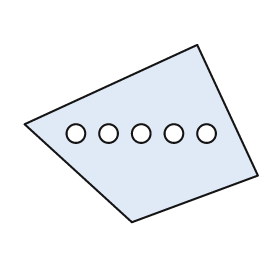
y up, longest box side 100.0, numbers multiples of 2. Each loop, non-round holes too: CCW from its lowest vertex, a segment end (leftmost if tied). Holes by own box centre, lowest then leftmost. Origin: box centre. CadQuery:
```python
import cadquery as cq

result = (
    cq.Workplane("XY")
    .moveTo(-4.0, -38.0)
    .lineTo(50.0, -18.0)
    .lineTo(24.0, 38.0)
    .lineTo(-50.0, 4.0)
    .close()
    .moveTo(-28.0, 0.0)
    .circle(4.0)
    .moveTo(-14.0, 0.0)
    .circle(4.0)
    .moveTo(0.0, 0.0)
    .circle(4.0)
    .moveTo(14.0, 0.0)
    .circle(4.0)
    .moveTo(28.0, 0.0)
    .circle(4.0)
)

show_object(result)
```